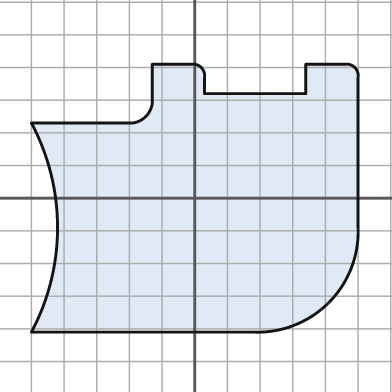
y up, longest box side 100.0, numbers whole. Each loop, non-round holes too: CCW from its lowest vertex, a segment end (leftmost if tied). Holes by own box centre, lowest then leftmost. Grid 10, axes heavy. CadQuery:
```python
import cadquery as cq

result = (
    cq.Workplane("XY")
    .moveTo(-50.0, -41.0)
    .lineTo(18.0, -41.0)
    .threePointArc((41.0, -32.0), (50.0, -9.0))
    .lineTo(50.0, 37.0)
    .threePointArc((49.0, 40.0), (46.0, 41.0))
    .lineTo(34.0, 41.0)
    .lineTo(34.0, 32.0)
    .lineTo(3.0, 32.0)
    .lineTo(3.0, 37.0)
    .threePointArc((2.0, 40.0), (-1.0, 41.0))
    .lineTo(-13.0, 41.0)
    .lineTo(-13.0, 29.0)
    .threePointArc((-15.0, 25.0), (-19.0, 23.0))
    .lineTo(-50.0, 23.0)
    .threePointArc((-42.0, -9.0), (-50.0, -41.0))
    .close()
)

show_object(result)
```